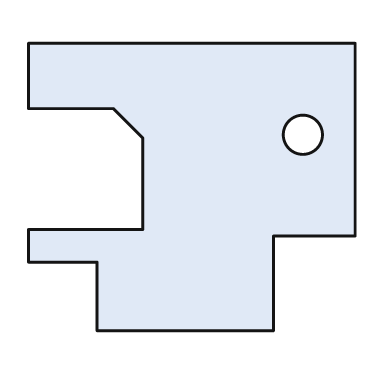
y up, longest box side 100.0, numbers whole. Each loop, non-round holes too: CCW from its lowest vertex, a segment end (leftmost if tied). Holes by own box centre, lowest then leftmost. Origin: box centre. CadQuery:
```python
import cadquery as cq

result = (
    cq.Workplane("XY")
    .moveTo(-29.0, -44.0)
    .lineTo(25.0, -44.0)
    .lineTo(25.0, -15.0)
    .lineTo(50.0, -15.0)
    .lineTo(50.0, 44.0)
    .lineTo(-50.0, 44.0)
    .lineTo(-50.0, 24.0)
    .lineTo(-24.0, 24.0)
    .lineTo(-15.0, 15.0)
    .lineTo(-15.0, -13.0)
    .lineTo(-50.0, -13.0)
    .lineTo(-50.0, -23.0)
    .lineTo(-29.0, -23.0)
    .close()
    .moveTo(34.0, 16.0)
    .circle(6.0)
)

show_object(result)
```